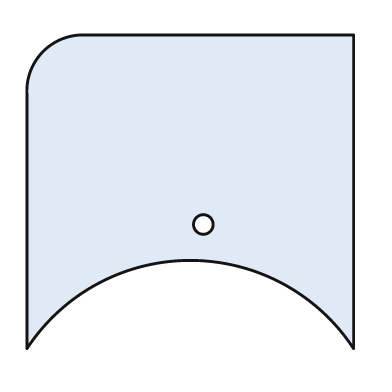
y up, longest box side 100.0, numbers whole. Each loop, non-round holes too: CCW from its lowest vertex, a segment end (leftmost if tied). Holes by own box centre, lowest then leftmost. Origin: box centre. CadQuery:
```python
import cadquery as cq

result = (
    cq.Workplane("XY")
    .moveTo(-50.0, -48.0)
    .threePointArc((0.0, -21.0), (50.0, -48.0))
    .lineTo(50.0, 48.0)
    .lineTo(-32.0, 48.0)
    .threePointArc((-45.0, 43.0), (-50.0, 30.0))
    .close()
    .moveTo(4.0, -10.0)
    .circle(3.0)
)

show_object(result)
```